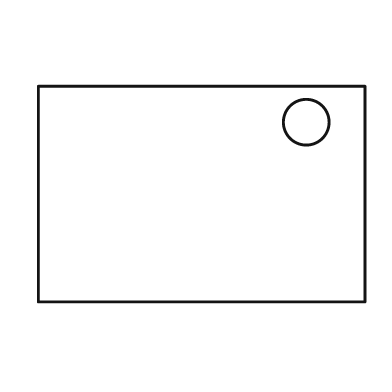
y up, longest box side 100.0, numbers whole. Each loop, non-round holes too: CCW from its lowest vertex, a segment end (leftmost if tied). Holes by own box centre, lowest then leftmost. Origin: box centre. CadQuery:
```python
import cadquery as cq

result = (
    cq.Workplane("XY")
    .moveTo(-50.0, -33.0)
    .lineTo(50.0, -33.0)
    .lineTo(50.0, 33.0)
    .lineTo(-50.0, 33.0)
    .close()
    .moveTo(32.0, 22.0)
    .circle(7.0)
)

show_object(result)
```